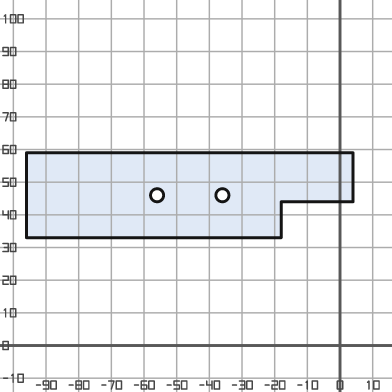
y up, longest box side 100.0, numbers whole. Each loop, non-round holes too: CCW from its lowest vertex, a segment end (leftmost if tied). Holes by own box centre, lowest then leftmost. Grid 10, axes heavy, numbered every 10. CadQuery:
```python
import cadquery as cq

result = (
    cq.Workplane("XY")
    .moveTo(-96.0, 33.0)
    .lineTo(-18.0, 33.0)
    .lineTo(-18.0, 44.0)
    .lineTo(4.0, 44.0)
    .lineTo(4.0, 59.0)
    .lineTo(-96.0, 59.0)
    .close()
    .moveTo(-56.0, 46.0)
    .circle(2.0)
    .moveTo(-36.0, 46.0)
    .circle(2.0)
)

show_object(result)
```